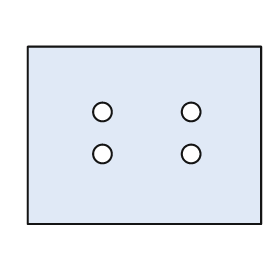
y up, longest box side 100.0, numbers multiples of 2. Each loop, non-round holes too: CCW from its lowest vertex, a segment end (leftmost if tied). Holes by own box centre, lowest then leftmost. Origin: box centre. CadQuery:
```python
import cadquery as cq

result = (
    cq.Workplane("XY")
    .moveTo(-50.0, -38.0)
    .lineTo(50.0, -38.0)
    .lineTo(50.0, 38.0)
    .lineTo(-50.0, 38.0)
    .close()
    .moveTo(-18.0, -8.0)
    .circle(4.0)
    .moveTo(20.0, -8.0)
    .circle(4.0)
    .moveTo(-18.0, 10.0)
    .circle(4.0)
    .moveTo(20.0, 10.0)
    .circle(4.0)
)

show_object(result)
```